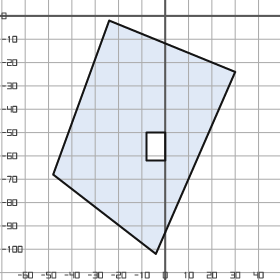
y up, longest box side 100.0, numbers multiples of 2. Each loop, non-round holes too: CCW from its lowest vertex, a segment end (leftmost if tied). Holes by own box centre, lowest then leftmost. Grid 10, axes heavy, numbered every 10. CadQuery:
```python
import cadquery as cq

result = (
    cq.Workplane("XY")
    .moveTo(-4.0, -102.0)
    .lineTo(30.0, -24.0)
    .lineTo(-24.0, -2.0)
    .lineTo(-48.0, -68.0)
    .close()
    .moveTo(-8.0, -62.0)
    .lineTo(0.0, -62.0)
    .lineTo(0.0, -50.0)
    .lineTo(-8.0, -50.0)
    .close()
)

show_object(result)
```